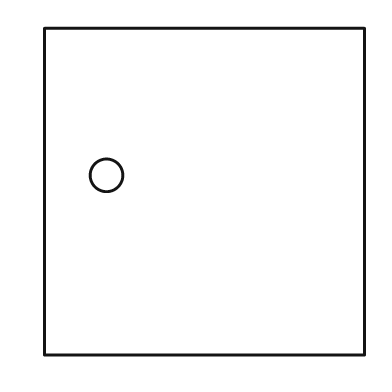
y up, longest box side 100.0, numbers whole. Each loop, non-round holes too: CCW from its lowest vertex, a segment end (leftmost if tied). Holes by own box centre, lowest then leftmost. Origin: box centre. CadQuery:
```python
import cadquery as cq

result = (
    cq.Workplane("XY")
    .moveTo(-49.0, -50.0)
    .lineTo(49.0, -50.0)
    .lineTo(49.0, 50.0)
    .lineTo(-49.0, 50.0)
    .close()
    .moveTo(-30.0, 5.0)
    .circle(5.0)
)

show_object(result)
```